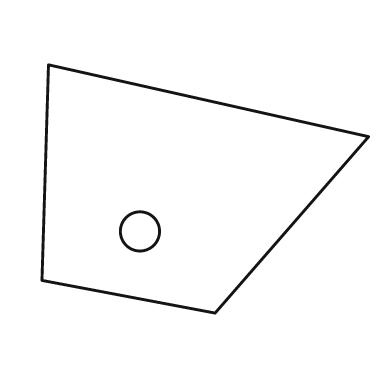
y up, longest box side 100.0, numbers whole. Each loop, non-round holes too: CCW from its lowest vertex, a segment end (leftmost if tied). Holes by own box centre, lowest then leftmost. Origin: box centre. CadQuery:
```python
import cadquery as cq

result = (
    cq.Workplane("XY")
    .moveTo(3.0, -38.0)
    .lineTo(50.0, 16.0)
    .lineTo(-48.0, 38.0)
    .lineTo(-50.0, -28.0)
    .close()
    .moveTo(-20.0, -13.0)
    .circle(6.0)
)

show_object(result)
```